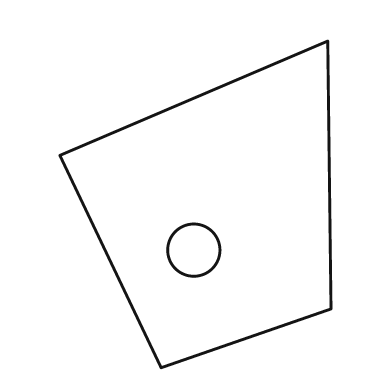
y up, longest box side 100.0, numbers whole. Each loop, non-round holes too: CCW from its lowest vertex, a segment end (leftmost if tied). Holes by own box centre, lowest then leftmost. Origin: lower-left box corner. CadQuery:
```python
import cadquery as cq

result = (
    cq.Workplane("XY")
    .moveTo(31.0, 0.0)
    .lineTo(83.0, 18.0)
    .lineTo(82.0, 100.0)
    .lineTo(0.0, 65.0)
    .close()
    .moveTo(41.0, 36.0)
    .circle(8.0)
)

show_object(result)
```